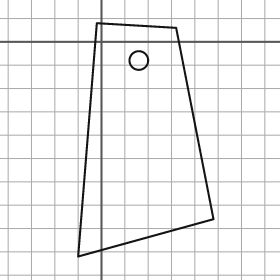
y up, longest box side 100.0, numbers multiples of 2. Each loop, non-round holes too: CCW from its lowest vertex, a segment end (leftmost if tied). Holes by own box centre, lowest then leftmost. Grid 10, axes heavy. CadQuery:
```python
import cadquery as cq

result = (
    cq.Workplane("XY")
    .moveTo(-10.0, -92.0)
    .lineTo(48.0, -76.0)
    .lineTo(32.0, 6.0)
    .lineTo(-2.0, 8.0)
    .close()
    .moveTo(16.0, -8.0)
    .circle(4.0)
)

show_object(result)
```